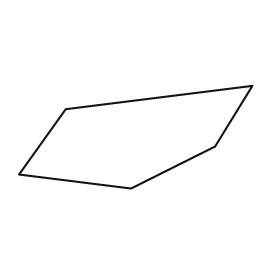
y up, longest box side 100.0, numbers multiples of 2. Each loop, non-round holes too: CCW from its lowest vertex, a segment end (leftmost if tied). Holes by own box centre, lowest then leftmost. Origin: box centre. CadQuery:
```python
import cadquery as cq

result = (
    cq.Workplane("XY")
    .moveTo(-2.0, -22.0)
    .lineTo(34.0, -4.0)
    .lineTo(50.0, 22.0)
    .lineTo(-30.0, 12.0)
    .lineTo(-50.0, -16.0)
    .close()
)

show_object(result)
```